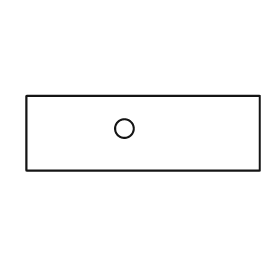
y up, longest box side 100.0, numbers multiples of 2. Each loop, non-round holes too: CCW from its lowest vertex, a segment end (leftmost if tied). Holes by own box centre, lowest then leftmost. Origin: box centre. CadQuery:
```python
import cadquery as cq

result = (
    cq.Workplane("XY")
    .moveTo(-50.0, -16.0)
    .lineTo(50.0, -16.0)
    .lineTo(50.0, 16.0)
    .lineTo(-50.0, 16.0)
    .close()
    .moveTo(-8.0, 2.0)
    .circle(4.0)
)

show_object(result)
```